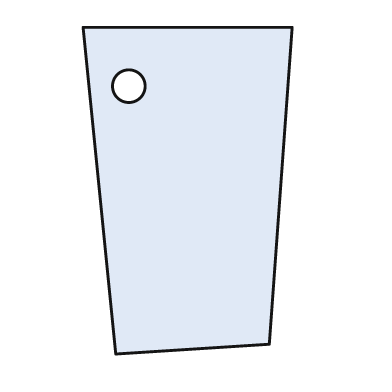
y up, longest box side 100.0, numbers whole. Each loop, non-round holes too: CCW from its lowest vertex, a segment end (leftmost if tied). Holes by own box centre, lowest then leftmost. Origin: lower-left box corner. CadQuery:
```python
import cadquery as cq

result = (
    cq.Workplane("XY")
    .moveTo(10.0, 0.0)
    .lineTo(57.0, 3.0)
    .lineTo(64.0, 100.0)
    .lineTo(0.0, 100.0)
    .close()
    .moveTo(14.0, 82.0)
    .circle(5.0)
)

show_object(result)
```